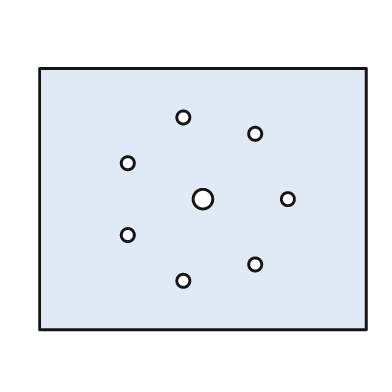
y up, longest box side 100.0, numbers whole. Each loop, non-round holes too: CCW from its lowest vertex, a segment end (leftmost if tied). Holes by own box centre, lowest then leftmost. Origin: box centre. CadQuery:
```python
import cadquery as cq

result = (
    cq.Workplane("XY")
    .moveTo(-50.0, -40.0)
    .lineTo(50.0, -40.0)
    .lineTo(50.0, 40.0)
    .lineTo(-50.0, 40.0)
    .close()
    .moveTo(-6.0, -25.0)
    .circle(2.0)
    .moveTo(16.0, -20.0)
    .circle(2.0)
    .moveTo(-23.0, -11.0)
    .circle(2.0)
    .moveTo(0.0, 0.0)
    .circle(3.0)
    .moveTo(26.0, 0.0)
    .circle(2.0)
    .moveTo(-23.0, 11.0)
    .circle(2.0)
    .moveTo(16.0, 20.0)
    .circle(2.0)
    .moveTo(-6.0, 25.0)
    .circle(2.0)
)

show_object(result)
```